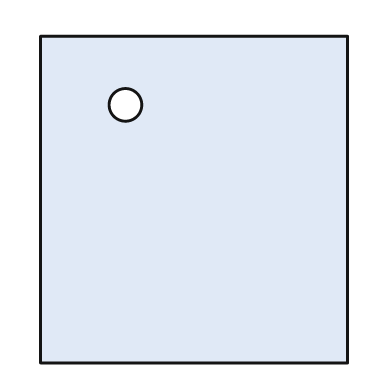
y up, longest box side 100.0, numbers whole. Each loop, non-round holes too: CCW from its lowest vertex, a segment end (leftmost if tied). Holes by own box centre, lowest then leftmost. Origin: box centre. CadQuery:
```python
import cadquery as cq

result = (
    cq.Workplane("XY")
    .moveTo(-47.0, -50.0)
    .lineTo(47.0, -50.0)
    .lineTo(47.0, 50.0)
    .lineTo(-47.0, 50.0)
    .close()
    .moveTo(-21.0, 29.0)
    .circle(5.0)
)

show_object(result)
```